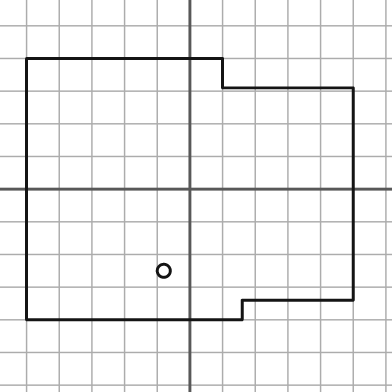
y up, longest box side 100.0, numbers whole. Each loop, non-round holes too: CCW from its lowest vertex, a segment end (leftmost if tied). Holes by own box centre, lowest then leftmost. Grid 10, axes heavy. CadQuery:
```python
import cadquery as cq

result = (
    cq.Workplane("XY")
    .moveTo(-50.0, -40.0)
    .lineTo(16.0, -40.0)
    .lineTo(16.0, -34.0)
    .lineTo(50.0, -34.0)
    .lineTo(50.0, 31.0)
    .lineTo(10.0, 31.0)
    .lineTo(10.0, 40.0)
    .lineTo(-50.0, 40.0)
    .close()
    .moveTo(-8.0, -25.0)
    .circle(2.0)
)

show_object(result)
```